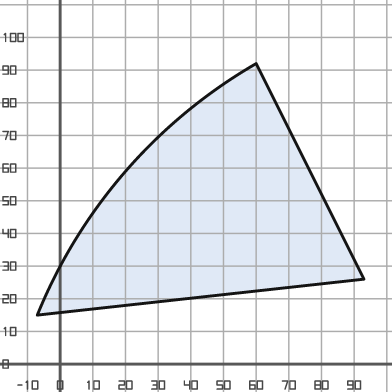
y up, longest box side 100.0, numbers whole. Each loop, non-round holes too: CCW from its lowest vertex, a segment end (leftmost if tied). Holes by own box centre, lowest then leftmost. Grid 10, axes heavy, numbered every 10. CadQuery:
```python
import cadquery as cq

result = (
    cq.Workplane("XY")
    .moveTo(-7.0, 15.0)
    .lineTo(93.0, 26.0)
    .lineTo(60.0, 92.0)
    .threePointArc((20.0, 59.0), (-7.0, 15.0))
    .close()
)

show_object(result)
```